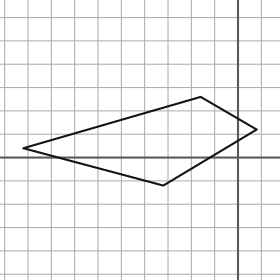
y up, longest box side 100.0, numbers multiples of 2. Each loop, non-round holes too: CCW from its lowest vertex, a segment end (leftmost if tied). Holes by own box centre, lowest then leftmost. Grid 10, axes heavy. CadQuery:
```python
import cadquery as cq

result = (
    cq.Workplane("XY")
    .moveTo(-32.0, -12.0)
    .lineTo(8.0, 12.0)
    .lineTo(-16.0, 26.0)
    .lineTo(-92.0, 4.0)
    .close()
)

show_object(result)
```